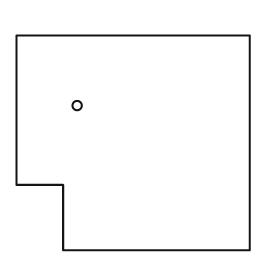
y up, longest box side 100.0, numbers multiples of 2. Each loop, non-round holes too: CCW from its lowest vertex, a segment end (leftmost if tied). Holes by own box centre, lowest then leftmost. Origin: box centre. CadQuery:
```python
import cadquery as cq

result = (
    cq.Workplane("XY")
    .moveTo(-30.0, -46.0)
    .lineTo(50.0, -46.0)
    .lineTo(50.0, 46.0)
    .lineTo(-50.0, 46.0)
    .lineTo(-50.0, -18.0)
    .lineTo(-30.0, -18.0)
    .close()
    .moveTo(-24.0, 16.0)
    .circle(2.0)
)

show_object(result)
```